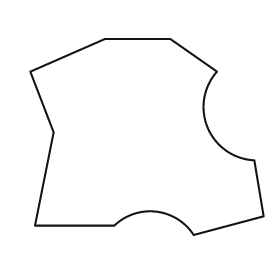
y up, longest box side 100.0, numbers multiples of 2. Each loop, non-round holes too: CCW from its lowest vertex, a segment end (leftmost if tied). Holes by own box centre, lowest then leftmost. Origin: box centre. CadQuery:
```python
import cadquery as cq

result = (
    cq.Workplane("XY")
    .moveTo(20.0, -42.0)
    .lineTo(50.0, -34.0)
    .lineTo(46.0, -10.0)
    .threePointArc((26.0, 4.0), (30.0, 28.0))
    .lineTo(10.0, 42.0)
    .lineTo(-18.0, 42.0)
    .lineTo(-50.0, 28.0)
    .lineTo(-40.0, 2.0)
    .lineTo(-48.0, -38.0)
    .lineTo(-14.0, -38.0)
    .threePointArc((4.0, -32.0), (20.0, -42.0))
    .close()
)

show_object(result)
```